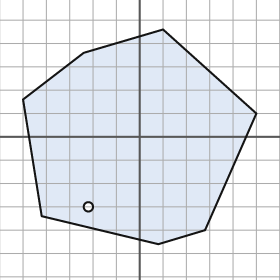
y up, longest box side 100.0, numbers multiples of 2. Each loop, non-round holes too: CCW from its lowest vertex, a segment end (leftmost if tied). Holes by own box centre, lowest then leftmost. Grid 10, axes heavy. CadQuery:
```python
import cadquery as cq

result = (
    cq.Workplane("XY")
    .moveTo(8.0, -46.0)
    .lineTo(28.0, -40.0)
    .lineTo(50.0, 10.0)
    .lineTo(10.0, 46.0)
    .lineTo(-24.0, 36.0)
    .lineTo(-50.0, 16.0)
    .lineTo(-42.0, -34.0)
    .close()
    .moveTo(-22.0, -30.0)
    .circle(2.0)
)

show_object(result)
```